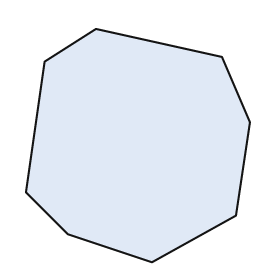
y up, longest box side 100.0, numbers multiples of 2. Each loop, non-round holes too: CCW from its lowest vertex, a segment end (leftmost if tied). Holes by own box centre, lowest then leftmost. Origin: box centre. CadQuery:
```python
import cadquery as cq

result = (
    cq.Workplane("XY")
    .moveTo(6.0, -50.0)
    .lineTo(42.0, -30.0)
    .lineTo(48.0, 10.0)
    .lineTo(36.0, 38.0)
    .lineTo(-18.0, 50.0)
    .lineTo(-40.0, 36.0)
    .lineTo(-48.0, -20.0)
    .lineTo(-30.0, -38.0)
    .close()
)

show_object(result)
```